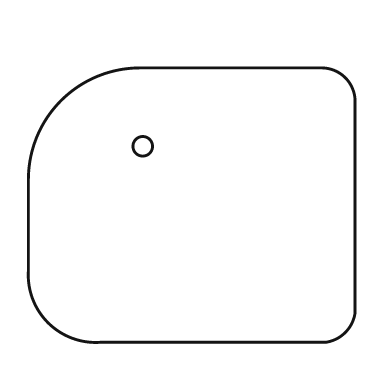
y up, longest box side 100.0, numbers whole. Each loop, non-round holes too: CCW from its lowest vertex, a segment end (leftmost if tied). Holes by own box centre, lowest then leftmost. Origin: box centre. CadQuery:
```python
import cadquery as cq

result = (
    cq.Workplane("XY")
    .moveTo(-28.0, -42.0)
    .lineTo(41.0, -42.0)
    .threePointArc((47.0, -39.0), (50.0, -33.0))
    .lineTo(50.0, 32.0)
    .threePointArc((47.0, 39.0), (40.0, 42.0))
    .lineTo(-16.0, 42.0)
    .threePointArc((-40.0, 32.0), (-50.0, 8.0))
    .lineTo(-50.0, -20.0)
    .threePointArc((-44.0, -36.0), (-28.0, -42.0))
    .close()
    .moveTo(-15.0, 18.0)
    .circle(3.0)
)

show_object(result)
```